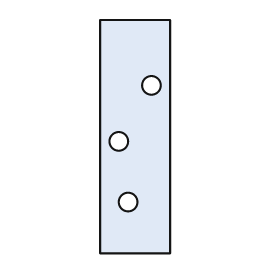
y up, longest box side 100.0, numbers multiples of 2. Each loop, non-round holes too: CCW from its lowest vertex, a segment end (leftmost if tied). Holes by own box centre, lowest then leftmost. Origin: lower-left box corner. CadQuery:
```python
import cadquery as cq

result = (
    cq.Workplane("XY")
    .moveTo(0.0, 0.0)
    .lineTo(30.0, 0.0)
    .lineTo(30.0, 100.0)
    .lineTo(0.0, 100.0)
    .close()
    .moveTo(12.0, 22.0)
    .circle(4.0)
    .moveTo(8.0, 48.0)
    .circle(4.0)
    .moveTo(22.0, 72.0)
    .circle(4.0)
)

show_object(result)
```